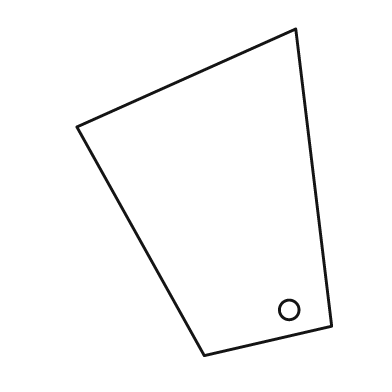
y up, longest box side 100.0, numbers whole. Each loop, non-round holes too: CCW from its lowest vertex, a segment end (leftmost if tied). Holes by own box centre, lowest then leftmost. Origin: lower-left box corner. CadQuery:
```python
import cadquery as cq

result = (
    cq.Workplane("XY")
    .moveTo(39.0, 0.0)
    .lineTo(78.0, 9.0)
    .lineTo(67.0, 100.0)
    .lineTo(0.0, 70.0)
    .close()
    .moveTo(65.0, 14.0)
    .circle(3.0)
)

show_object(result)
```